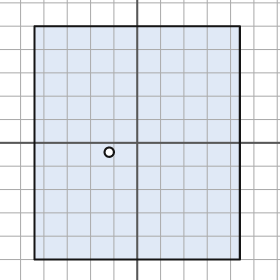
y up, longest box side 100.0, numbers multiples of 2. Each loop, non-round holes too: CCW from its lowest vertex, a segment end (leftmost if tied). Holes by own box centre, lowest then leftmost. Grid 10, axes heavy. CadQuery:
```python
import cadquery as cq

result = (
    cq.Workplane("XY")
    .moveTo(-44.0, -50.0)
    .lineTo(44.0, -50.0)
    .lineTo(44.0, 50.0)
    .lineTo(-44.0, 50.0)
    .close()
    .moveTo(-12.0, -4.0)
    .circle(2.0)
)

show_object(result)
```